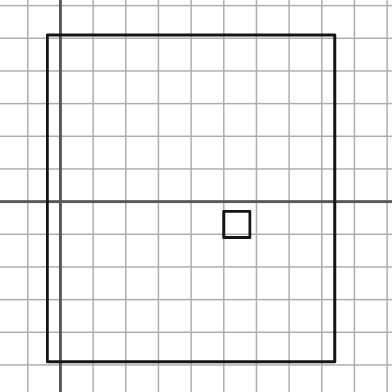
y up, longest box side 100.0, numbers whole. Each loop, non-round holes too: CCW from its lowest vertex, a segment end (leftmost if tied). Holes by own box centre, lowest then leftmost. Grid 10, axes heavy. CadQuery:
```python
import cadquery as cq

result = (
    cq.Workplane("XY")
    .moveTo(-4.0, -49.0)
    .lineTo(84.0, -49.0)
    .lineTo(84.0, 51.0)
    .lineTo(-4.0, 51.0)
    .close()
    .moveTo(50.0, -11.0)
    .lineTo(58.0, -11.0)
    .lineTo(58.0, -3.0)
    .lineTo(50.0, -3.0)
    .close()
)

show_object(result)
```